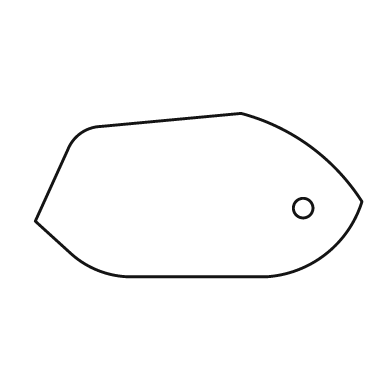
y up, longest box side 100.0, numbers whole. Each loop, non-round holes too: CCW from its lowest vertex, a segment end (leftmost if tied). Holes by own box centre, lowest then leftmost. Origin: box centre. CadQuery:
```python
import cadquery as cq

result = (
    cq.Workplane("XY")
    .moveTo(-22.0, -25.0)
    .lineTo(21.0, -25.0)
    .threePointArc((39.0, -18.0), (50.0, -2.0))
    .threePointArc((34.0, 15.0), (13.0, 25.0))
    .lineTo(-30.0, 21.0)
    .threePointArc((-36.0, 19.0), (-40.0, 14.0))
    .lineTo(-50.0, -8.0)
    .lineTo(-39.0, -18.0)
    .threePointArc((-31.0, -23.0), (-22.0, -25.0))
    .close()
    .moveTo(32.0, -4.0)
    .circle(3.0)
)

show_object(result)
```